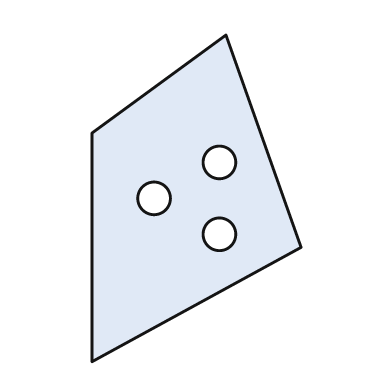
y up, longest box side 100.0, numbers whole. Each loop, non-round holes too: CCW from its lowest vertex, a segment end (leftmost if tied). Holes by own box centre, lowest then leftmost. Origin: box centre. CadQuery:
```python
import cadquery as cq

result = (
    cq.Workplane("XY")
    .moveTo(-32.0, -50.0)
    .lineTo(32.0, -15.0)
    .lineTo(9.0, 50.0)
    .lineTo(-32.0, 20.0)
    .close()
    .moveTo(7.0, -11.0)
    .circle(5.0)
    .moveTo(-13.0, 0.0)
    .circle(5.0)
    .moveTo(7.0, 11.0)
    .circle(5.0)
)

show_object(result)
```